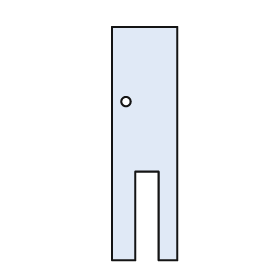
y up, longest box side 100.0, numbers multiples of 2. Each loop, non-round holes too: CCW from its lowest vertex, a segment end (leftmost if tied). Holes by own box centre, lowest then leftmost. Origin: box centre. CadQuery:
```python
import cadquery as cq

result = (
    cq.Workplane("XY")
    .moveTo(-14.0, -50.0)
    .lineTo(-4.0, -50.0)
    .lineTo(-4.0, -12.0)
    .lineTo(6.0, -12.0)
    .lineTo(6.0, -50.0)
    .lineTo(14.0, -50.0)
    .lineTo(14.0, 50.0)
    .lineTo(-14.0, 50.0)
    .close()
    .moveTo(-8.0, 18.0)
    .circle(2.0)
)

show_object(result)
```